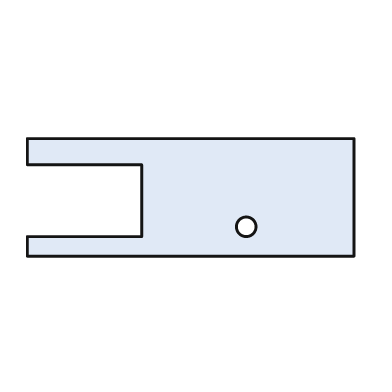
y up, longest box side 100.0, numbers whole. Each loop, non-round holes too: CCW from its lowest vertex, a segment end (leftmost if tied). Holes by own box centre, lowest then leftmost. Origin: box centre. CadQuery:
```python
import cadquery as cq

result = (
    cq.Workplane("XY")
    .moveTo(-50.0, -18.0)
    .lineTo(50.0, -18.0)
    .lineTo(50.0, 18.0)
    .lineTo(-50.0, 18.0)
    .lineTo(-50.0, 10.0)
    .lineTo(-15.0, 10.0)
    .lineTo(-15.0, -12.0)
    .lineTo(-50.0, -12.0)
    .close()
    .moveTo(17.0, -9.0)
    .circle(3.0)
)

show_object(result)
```